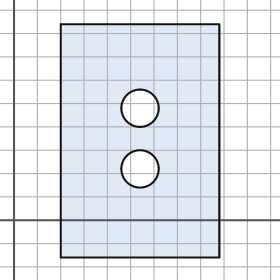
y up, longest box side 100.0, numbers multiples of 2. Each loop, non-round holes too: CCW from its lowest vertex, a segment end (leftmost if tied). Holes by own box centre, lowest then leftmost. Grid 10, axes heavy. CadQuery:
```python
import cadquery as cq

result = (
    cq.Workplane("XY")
    .moveTo(20.0, -16.0)
    .lineTo(88.0, -16.0)
    .lineTo(88.0, 84.0)
    .lineTo(20.0, 84.0)
    .close()
    .moveTo(54.0, 22.0)
    .circle(8.0)
    .moveTo(54.0, 48.0)
    .circle(8.0)
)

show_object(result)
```